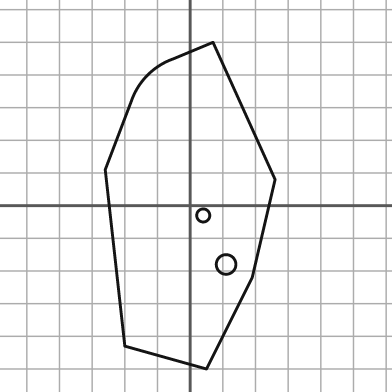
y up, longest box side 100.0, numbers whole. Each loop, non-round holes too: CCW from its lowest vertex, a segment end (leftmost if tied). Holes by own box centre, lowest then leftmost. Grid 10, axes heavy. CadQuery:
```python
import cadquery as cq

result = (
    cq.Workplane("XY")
    .moveTo(5.0, -50.0)
    .lineTo(19.0, -22.0)
    .lineTo(26.0, 8.0)
    .lineTo(7.0, 50.0)
    .lineTo(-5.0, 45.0)
    .threePointArc((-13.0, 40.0), (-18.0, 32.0))
    .lineTo(-26.0, 11.0)
    .lineTo(-20.0, -43.0)
    .close()
    .moveTo(11.0, -18.0)
    .circle(3.0)
    .moveTo(4.0, -3.0)
    .circle(2.0)
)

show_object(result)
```